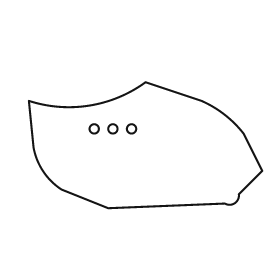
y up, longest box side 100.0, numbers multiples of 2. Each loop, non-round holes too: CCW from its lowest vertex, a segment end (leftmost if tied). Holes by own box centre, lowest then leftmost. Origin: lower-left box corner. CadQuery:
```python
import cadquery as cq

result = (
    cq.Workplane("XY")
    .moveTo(34.0, 0.0)
    .lineTo(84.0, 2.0)
    .threePointArc((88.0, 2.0), (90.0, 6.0))
    .lineTo(100.0, 16.0)
    .lineTo(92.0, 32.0)
    .threePointArc((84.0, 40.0), (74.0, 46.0))
    .lineTo(50.0, 54.0)
    .threePointArc((26.0, 44.0), (0.0, 46.0))
    .lineTo(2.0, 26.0)
    .threePointArc((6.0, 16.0), (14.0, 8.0))
    .close()
    .moveTo(28.0, 34.0)
    .circle(2.0)
    .moveTo(36.0, 34.0)
    .circle(2.0)
    .moveTo(44.0, 34.0)
    .circle(2.0)
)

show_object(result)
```